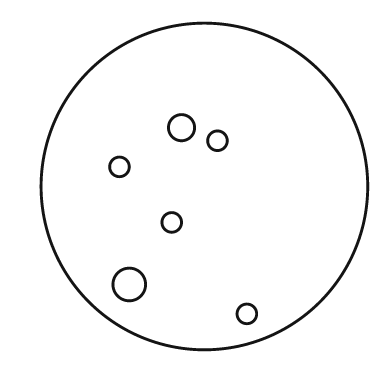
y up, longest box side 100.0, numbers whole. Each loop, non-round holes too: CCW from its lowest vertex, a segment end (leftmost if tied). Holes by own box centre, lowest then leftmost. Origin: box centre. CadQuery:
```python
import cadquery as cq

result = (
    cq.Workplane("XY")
    .moveTo(0.0, 0.0)
    .circle(50.0)
    .moveTo(13.0, -39.0)
    .circle(3.0)
    .moveTo(-23.0, -30.0)
    .circle(5.0)
    .moveTo(-10.0, -11.0)
    .circle(3.0)
    .moveTo(-26.0, 6.0)
    .circle(3.0)
    .moveTo(4.0, 14.0)
    .circle(3.0)
    .moveTo(-7.0, 18.0)
    .circle(4.0)
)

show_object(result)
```